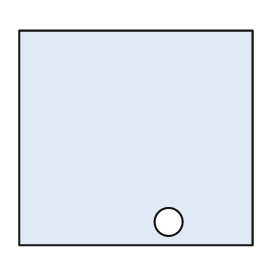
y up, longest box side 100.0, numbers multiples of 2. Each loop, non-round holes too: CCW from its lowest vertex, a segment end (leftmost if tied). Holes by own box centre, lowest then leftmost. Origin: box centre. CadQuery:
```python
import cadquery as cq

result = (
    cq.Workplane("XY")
    .moveTo(-50.0, -46.0)
    .lineTo(50.0, -46.0)
    .lineTo(50.0, 46.0)
    .lineTo(-50.0, 46.0)
    .close()
    .moveTo(14.0, -36.0)
    .circle(6.0)
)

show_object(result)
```